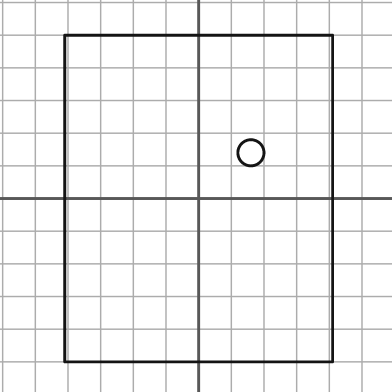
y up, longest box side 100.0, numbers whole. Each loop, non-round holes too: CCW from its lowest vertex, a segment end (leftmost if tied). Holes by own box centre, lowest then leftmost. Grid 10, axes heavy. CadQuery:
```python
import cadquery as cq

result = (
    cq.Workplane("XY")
    .moveTo(-41.0, -50.0)
    .lineTo(41.0, -50.0)
    .lineTo(41.0, 50.0)
    .lineTo(-41.0, 50.0)
    .close()
    .moveTo(16.0, 14.0)
    .circle(4.0)
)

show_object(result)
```